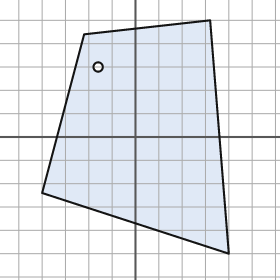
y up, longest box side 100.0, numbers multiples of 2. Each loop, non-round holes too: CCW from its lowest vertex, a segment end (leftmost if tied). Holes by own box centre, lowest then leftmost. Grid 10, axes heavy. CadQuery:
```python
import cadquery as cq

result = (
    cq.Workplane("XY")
    .moveTo(40.0, -50.0)
    .lineTo(32.0, 50.0)
    .lineTo(-22.0, 44.0)
    .lineTo(-40.0, -24.0)
    .close()
    .moveTo(-16.0, 30.0)
    .circle(2.0)
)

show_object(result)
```